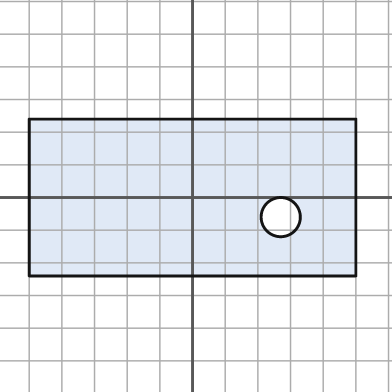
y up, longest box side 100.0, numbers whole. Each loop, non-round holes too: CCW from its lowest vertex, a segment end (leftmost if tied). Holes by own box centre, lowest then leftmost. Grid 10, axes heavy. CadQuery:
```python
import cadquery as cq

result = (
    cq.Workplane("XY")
    .moveTo(-50.0, -24.0)
    .lineTo(50.0, -24.0)
    .lineTo(50.0, 24.0)
    .lineTo(-50.0, 24.0)
    .close()
    .moveTo(27.0, -6.0)
    .circle(6.0)
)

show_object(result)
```